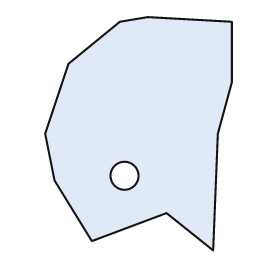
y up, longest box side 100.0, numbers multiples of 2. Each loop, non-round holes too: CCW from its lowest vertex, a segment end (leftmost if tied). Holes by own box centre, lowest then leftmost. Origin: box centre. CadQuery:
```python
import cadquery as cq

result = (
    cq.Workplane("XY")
    .moveTo(32.0, -50.0)
    .lineTo(34.0, 0.0)
    .lineTo(40.0, 22.0)
    .lineTo(40.0, 48.0)
    .lineTo(4.0, 50.0)
    .lineTo(-8.0, 48.0)
    .lineTo(-30.0, 30.0)
    .lineTo(-40.0, 0.0)
    .lineTo(-36.0, -20.0)
    .lineTo(-20.0, -46.0)
    .lineTo(12.0, -34.0)
    .close()
    .moveTo(-6.0, -18.0)
    .circle(6.0)
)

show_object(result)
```